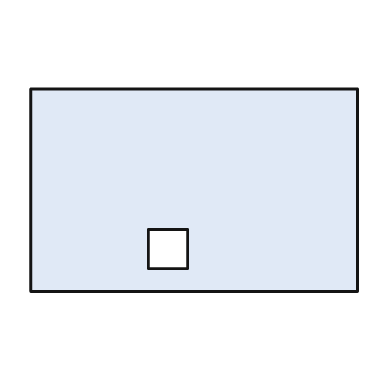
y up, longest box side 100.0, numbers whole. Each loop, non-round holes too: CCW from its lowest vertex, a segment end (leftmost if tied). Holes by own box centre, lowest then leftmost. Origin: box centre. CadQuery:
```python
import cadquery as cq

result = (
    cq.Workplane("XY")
    .moveTo(-50.0, -31.0)
    .lineTo(50.0, -31.0)
    .lineTo(50.0, 31.0)
    .lineTo(-50.0, 31.0)
    .close()
    .moveTo(-14.0, -24.0)
    .lineTo(-2.0, -24.0)
    .lineTo(-2.0, -12.0)
    .lineTo(-14.0, -12.0)
    .close()
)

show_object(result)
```